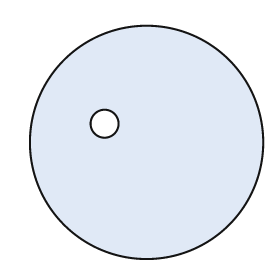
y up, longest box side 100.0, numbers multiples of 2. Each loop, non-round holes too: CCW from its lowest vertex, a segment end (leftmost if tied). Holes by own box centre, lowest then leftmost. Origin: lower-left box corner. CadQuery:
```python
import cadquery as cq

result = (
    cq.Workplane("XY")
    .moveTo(50.0, 50.0)
    .circle(50.0)
    .moveTo(32.0, 58.0)
    .circle(6.0)
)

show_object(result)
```